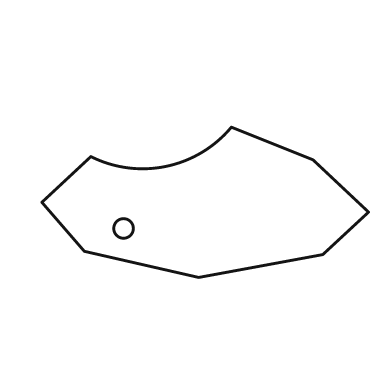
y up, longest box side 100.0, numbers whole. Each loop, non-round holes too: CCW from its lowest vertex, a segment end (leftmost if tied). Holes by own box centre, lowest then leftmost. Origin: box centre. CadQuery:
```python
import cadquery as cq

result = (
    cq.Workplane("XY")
    .moveTo(-2.0, -23.0)
    .lineTo(36.0, -16.0)
    .lineTo(50.0, -3.0)
    .lineTo(33.0, 13.0)
    .lineTo(8.0, 23.0)
    .threePointArc((-12.0, 11.0), (-35.0, 14.0))
    .lineTo(-50.0, 0.0)
    .lineTo(-37.0, -15.0)
    .close()
    .moveTo(-25.0, -8.0)
    .circle(3.0)
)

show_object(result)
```